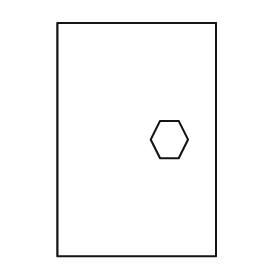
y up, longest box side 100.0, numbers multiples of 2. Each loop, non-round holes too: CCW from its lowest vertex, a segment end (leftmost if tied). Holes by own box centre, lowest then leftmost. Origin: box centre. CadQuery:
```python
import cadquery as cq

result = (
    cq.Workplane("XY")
    .moveTo(-34.0, -50.0)
    .lineTo(34.0, -50.0)
    .lineTo(34.0, 50.0)
    .lineTo(-34.0, 50.0)
    .close()
    .moveTo(10.0, -8.0)
    .lineTo(18.0, -8.0)
    .lineTo(22.0, 0.0)
    .lineTo(18.0, 8.0)
    .lineTo(10.0, 8.0)
    .lineTo(6.0, 0.0)
    .close()
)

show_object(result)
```